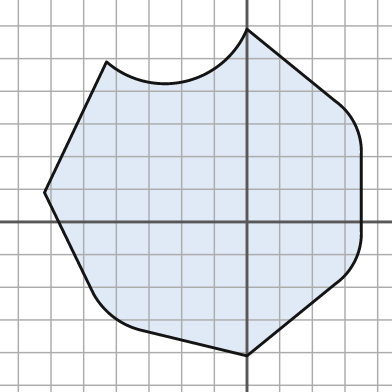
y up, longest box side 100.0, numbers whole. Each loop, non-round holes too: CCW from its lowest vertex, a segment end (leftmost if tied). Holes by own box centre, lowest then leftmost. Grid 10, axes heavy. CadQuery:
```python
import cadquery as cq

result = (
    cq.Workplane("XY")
    .moveTo(0.0, -41.0)
    .lineTo(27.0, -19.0)
    .threePointArc((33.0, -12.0), (35.0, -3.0))
    .lineTo(35.0, 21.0)
    .threePointArc((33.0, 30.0), (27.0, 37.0))
    .lineTo(0.0, 59.0)
    .threePointArc((-19.0, 43.0), (-43.0, 49.0))
    .lineTo(-62.0, 9.0)
    .lineTo(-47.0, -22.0)
    .threePointArc((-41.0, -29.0), (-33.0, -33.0))
    .close()
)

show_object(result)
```